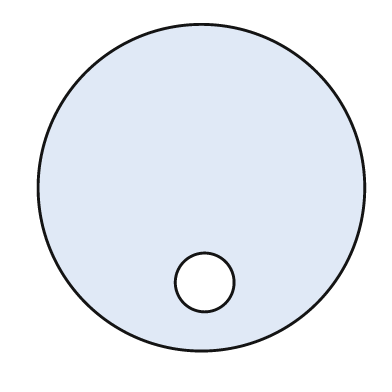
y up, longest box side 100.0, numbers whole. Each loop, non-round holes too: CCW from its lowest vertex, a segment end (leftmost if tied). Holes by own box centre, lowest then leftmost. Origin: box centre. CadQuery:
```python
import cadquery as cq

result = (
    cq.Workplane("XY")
    .moveTo(0.0, 0.0)
    .circle(50.0)
    .moveTo(1.0, -29.0)
    .circle(9.0)
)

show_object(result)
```